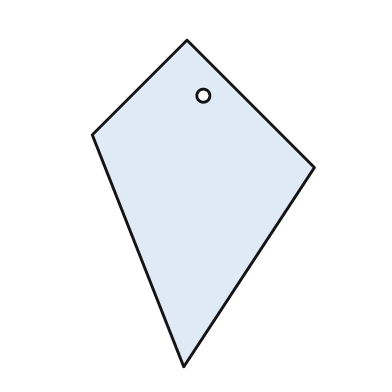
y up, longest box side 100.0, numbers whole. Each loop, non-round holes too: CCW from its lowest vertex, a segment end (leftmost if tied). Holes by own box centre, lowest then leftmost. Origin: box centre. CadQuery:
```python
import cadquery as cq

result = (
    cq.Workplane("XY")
    .moveTo(-6.0, -50.0)
    .lineTo(34.0, 11.0)
    .lineTo(-5.0, 50.0)
    .lineTo(-34.0, 21.0)
    .close()
    .moveTo(0.0, 33.0)
    .circle(2.0)
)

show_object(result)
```